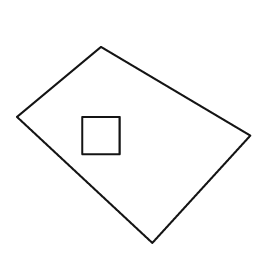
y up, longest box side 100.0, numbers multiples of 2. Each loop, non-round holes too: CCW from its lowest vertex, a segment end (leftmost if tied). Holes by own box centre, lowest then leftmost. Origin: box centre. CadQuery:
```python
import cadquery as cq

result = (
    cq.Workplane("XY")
    .moveTo(8.0, -42.0)
    .lineTo(50.0, 4.0)
    .lineTo(-14.0, 42.0)
    .lineTo(-50.0, 12.0)
    .close()
    .moveTo(-22.0, -4.0)
    .lineTo(-6.0, -4.0)
    .lineTo(-6.0, 12.0)
    .lineTo(-22.0, 12.0)
    .close()
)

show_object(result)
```